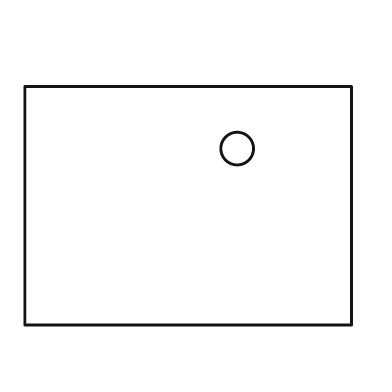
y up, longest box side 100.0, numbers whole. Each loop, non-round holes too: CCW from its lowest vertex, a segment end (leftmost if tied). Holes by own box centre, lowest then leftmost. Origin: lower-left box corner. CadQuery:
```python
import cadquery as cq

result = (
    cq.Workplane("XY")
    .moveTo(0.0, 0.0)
    .lineTo(100.0, 0.0)
    .lineTo(100.0, 73.0)
    .lineTo(0.0, 73.0)
    .close()
    .moveTo(65.0, 54.0)
    .circle(5.0)
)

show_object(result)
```